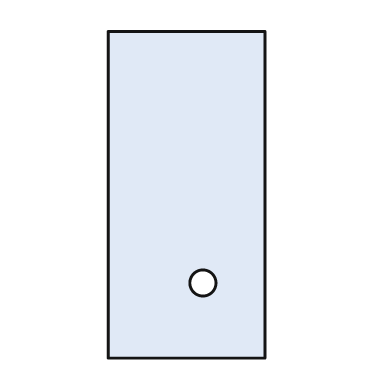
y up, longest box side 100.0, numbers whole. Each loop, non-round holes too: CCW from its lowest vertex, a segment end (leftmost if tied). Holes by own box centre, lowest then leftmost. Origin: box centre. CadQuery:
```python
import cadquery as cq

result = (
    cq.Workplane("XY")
    .moveTo(-24.0, -50.0)
    .lineTo(24.0, -50.0)
    .lineTo(24.0, 50.0)
    .lineTo(-24.0, 50.0)
    .close()
    .moveTo(5.0, -27.0)
    .circle(4.0)
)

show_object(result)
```